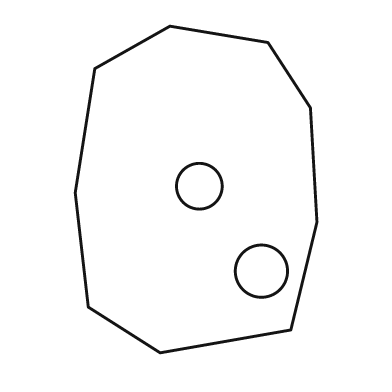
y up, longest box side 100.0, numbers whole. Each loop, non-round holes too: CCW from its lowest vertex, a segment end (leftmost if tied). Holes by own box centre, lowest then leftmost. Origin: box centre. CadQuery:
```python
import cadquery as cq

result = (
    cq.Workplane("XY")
    .moveTo(-11.0, -50.0)
    .lineTo(29.0, -43.0)
    .lineTo(37.0, -10.0)
    .lineTo(35.0, 25.0)
    .lineTo(22.0, 45.0)
    .lineTo(-8.0, 50.0)
    .lineTo(-31.0, 37.0)
    .lineTo(-37.0, -1.0)
    .lineTo(-33.0, -36.0)
    .close()
    .moveTo(20.0, -25.0)
    .circle(8.0)
    .moveTo(1.0, 1.0)
    .circle(7.0)
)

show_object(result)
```